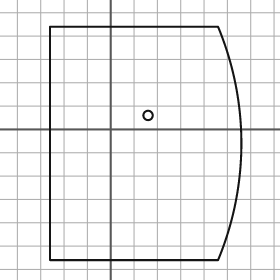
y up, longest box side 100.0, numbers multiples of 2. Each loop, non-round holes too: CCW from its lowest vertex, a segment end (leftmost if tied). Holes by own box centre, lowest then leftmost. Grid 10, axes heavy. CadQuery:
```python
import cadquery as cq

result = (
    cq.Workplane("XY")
    .moveTo(-26.0, -56.0)
    .lineTo(46.0, -56.0)
    .threePointArc((56.0, -6.0), (46.0, 44.0))
    .lineTo(-26.0, 44.0)
    .close()
    .moveTo(16.0, 6.0)
    .circle(2.0)
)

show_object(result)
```